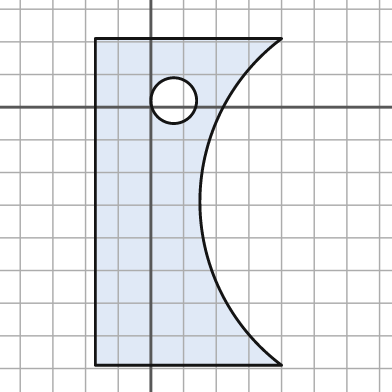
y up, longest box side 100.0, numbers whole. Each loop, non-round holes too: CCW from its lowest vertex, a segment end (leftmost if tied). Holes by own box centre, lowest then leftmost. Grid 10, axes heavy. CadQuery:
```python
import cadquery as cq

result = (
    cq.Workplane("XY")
    .moveTo(-17.0, -79.0)
    .lineTo(40.0, -79.0)
    .threePointArc((15.0, -29.0), (40.0, 21.0))
    .lineTo(-17.0, 21.0)
    .close()
    .moveTo(7.0, 2.0)
    .circle(7.0)
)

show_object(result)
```